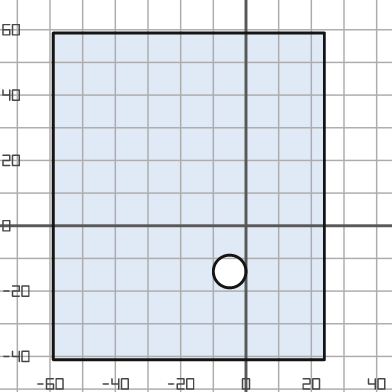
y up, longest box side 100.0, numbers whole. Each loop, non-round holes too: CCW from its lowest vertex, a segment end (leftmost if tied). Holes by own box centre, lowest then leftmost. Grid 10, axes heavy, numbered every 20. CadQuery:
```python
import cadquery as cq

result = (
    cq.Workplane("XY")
    .moveTo(-59.0, -41.0)
    .lineTo(24.0, -41.0)
    .lineTo(24.0, 59.0)
    .lineTo(-59.0, 59.0)
    .close()
    .moveTo(-5.0, -14.0)
    .circle(5.0)
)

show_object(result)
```